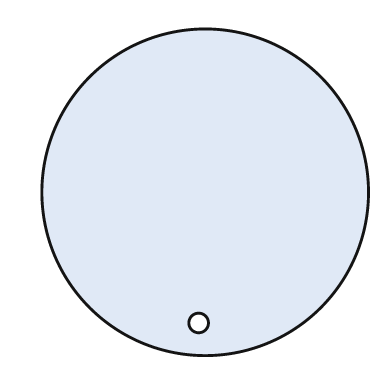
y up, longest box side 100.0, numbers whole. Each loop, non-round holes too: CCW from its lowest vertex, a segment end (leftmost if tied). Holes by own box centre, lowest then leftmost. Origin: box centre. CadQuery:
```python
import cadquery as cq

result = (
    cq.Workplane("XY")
    .moveTo(0.0, 0.0)
    .circle(50.0)
    .moveTo(-2.0, -40.0)
    .circle(3.0)
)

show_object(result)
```